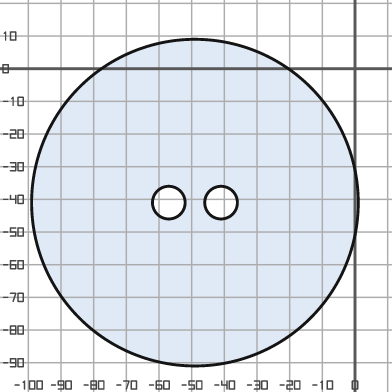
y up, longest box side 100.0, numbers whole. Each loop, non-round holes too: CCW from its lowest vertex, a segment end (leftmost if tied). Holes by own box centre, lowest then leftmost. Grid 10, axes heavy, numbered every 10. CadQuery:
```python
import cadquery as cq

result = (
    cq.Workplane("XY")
    .moveTo(-49.0, -41.0)
    .circle(50.0)
    .moveTo(-57.0, -41.0)
    .circle(5.0)
    .moveTo(-41.0, -41.0)
    .circle(5.0)
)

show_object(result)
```